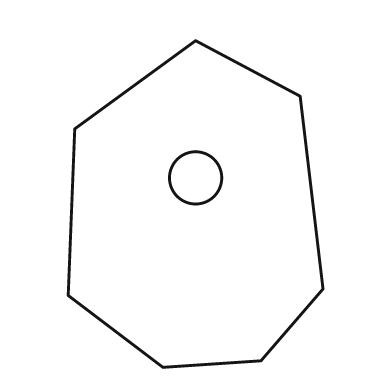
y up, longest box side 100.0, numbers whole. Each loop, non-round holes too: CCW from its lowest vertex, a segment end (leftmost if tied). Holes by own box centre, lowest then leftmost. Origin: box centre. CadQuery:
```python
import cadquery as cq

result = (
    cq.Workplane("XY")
    .moveTo(-10.0, -50.0)
    .lineTo(20.0, -48.0)
    .lineTo(39.0, -26.0)
    .lineTo(32.0, 33.0)
    .lineTo(0.0, 50.0)
    .lineTo(-37.0, 23.0)
    .lineTo(-39.0, -28.0)
    .close()
    .moveTo(0.0, 8.0)
    .circle(8.0)
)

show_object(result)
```